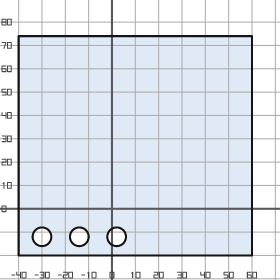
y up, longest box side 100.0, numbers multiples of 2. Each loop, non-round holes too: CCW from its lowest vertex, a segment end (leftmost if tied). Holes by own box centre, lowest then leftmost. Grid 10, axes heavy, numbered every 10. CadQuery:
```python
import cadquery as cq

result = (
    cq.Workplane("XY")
    .moveTo(-40.0, -20.0)
    .lineTo(60.0, -20.0)
    .lineTo(60.0, 74.0)
    .lineTo(-40.0, 74.0)
    .close()
    .moveTo(-30.0, -12.0)
    .circle(4.0)
    .moveTo(-14.0, -12.0)
    .circle(4.0)
    .moveTo(2.0, -12.0)
    .circle(4.0)
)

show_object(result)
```